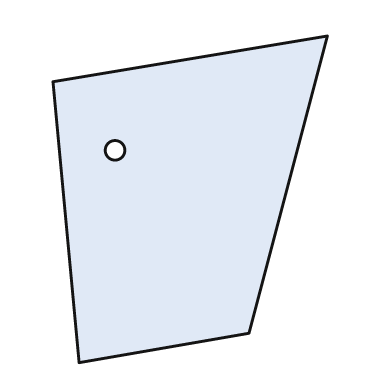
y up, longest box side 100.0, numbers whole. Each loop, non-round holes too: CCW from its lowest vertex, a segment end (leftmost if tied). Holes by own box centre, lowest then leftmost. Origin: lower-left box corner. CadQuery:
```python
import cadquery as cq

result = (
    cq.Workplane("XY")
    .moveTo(8.0, 0.0)
    .lineTo(60.0, 9.0)
    .lineTo(84.0, 100.0)
    .lineTo(0.0, 86.0)
    .close()
    .moveTo(19.0, 65.0)
    .circle(3.0)
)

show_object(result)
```